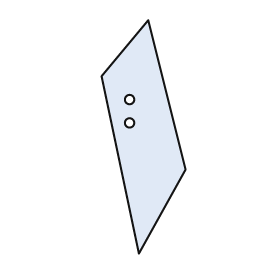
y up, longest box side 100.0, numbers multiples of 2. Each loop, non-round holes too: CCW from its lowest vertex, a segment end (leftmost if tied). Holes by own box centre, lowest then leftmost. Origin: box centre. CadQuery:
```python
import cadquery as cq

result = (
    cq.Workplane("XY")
    .moveTo(-2.0, -50.0)
    .lineTo(18.0, -14.0)
    .lineTo(2.0, 50.0)
    .lineTo(-18.0, 26.0)
    .close()
    .moveTo(-6.0, 6.0)
    .circle(2.0)
    .moveTo(-6.0, 16.0)
    .circle(2.0)
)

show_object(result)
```